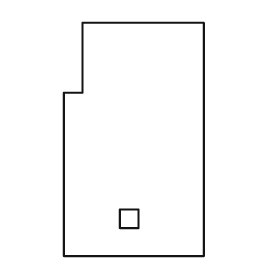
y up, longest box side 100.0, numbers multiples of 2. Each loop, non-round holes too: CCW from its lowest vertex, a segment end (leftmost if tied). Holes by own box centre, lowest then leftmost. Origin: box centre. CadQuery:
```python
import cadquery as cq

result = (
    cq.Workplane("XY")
    .moveTo(-30.0, -50.0)
    .lineTo(30.0, -50.0)
    .lineTo(30.0, 50.0)
    .lineTo(-22.0, 50.0)
    .lineTo(-22.0, 20.0)
    .lineTo(-30.0, 20.0)
    .close()
    .moveTo(-6.0, -38.0)
    .lineTo(2.0, -38.0)
    .lineTo(2.0, -30.0)
    .lineTo(-6.0, -30.0)
    .close()
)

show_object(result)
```